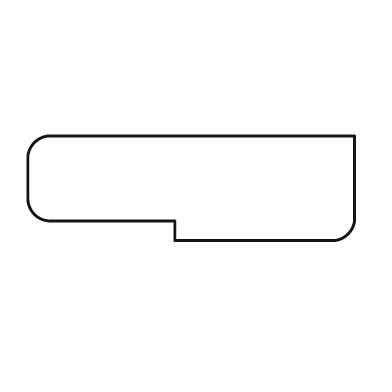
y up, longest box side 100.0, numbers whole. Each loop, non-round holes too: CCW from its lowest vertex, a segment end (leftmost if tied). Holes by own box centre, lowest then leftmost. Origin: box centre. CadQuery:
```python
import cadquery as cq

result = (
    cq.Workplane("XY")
    .moveTo(-5.0, -16.0)
    .lineTo(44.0, -16.0)
    .threePointArc((48.0, -14.0), (50.0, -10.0))
    .lineTo(50.0, 16.0)
    .lineTo(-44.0, 16.0)
    .threePointArc((-48.0, 14.0), (-50.0, 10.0))
    .lineTo(-50.0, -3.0)
    .threePointArc((-48.0, -8.0), (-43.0, -10.0))
    .lineTo(-5.0, -10.0)
    .close()
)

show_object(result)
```